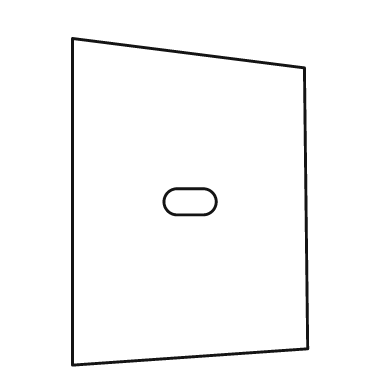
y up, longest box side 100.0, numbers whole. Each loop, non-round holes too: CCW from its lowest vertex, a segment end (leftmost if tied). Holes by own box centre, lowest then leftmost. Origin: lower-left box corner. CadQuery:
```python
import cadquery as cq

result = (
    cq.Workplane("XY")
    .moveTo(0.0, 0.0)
    .lineTo(72.0, 5.0)
    .lineTo(71.0, 91.0)
    .lineTo(0.0, 100.0)
    .close()
    .moveTo(32.0, 46.0)
    .lineTo(40.0, 46.0)
    .threePointArc((44.0, 50.0), (40.0, 54.0))
    .lineTo(32.0, 54.0)
    .threePointArc((28.0, 50.0), (32.0, 46.0))
    .close()
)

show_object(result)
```